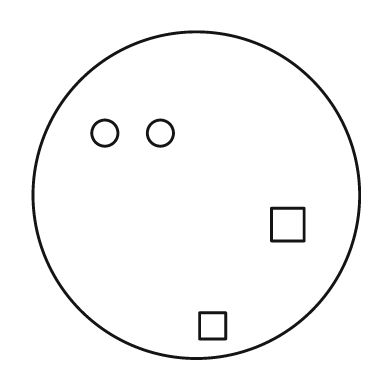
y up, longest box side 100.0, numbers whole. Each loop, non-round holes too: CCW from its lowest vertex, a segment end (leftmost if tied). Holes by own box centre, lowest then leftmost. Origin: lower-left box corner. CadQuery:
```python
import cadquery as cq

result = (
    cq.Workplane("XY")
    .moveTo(50.0, 50.0)
    .circle(50.0)
    .moveTo(51.0, 6.0)
    .lineTo(59.0, 6.0)
    .lineTo(59.0, 14.0)
    .lineTo(51.0, 14.0)
    .close()
    .moveTo(73.0, 36.0)
    .lineTo(83.0, 36.0)
    .lineTo(83.0, 46.0)
    .lineTo(73.0, 46.0)
    .close()
    .moveTo(22.0, 69.0)
    .circle(4.0)
    .moveTo(39.0, 69.0)
    .circle(4.0)
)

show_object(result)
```